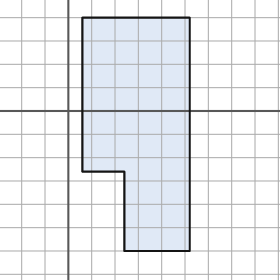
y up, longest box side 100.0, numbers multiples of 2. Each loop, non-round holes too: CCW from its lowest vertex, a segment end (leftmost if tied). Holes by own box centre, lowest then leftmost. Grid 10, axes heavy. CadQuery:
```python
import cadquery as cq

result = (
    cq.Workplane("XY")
    .moveTo(24.0, -60.0)
    .lineTo(52.0, -60.0)
    .lineTo(52.0, 40.0)
    .lineTo(6.0, 40.0)
    .lineTo(6.0, -26.0)
    .lineTo(24.0, -26.0)
    .close()
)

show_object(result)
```